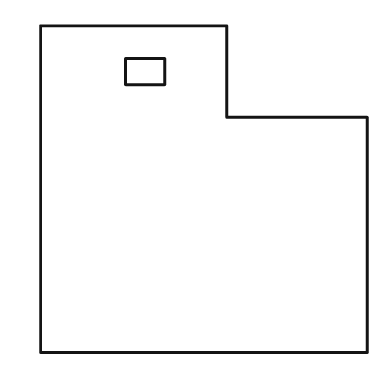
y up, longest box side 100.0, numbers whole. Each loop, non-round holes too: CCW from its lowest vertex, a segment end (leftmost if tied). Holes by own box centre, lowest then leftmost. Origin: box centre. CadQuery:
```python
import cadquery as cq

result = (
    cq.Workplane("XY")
    .moveTo(-50.0, -50.0)
    .lineTo(50.0, -50.0)
    .lineTo(50.0, 22.0)
    .lineTo(7.0, 22.0)
    .lineTo(7.0, 50.0)
    .lineTo(-50.0, 50.0)
    .close()
    .moveTo(-24.0, 32.0)
    .lineTo(-12.0, 32.0)
    .lineTo(-12.0, 40.0)
    .lineTo(-24.0, 40.0)
    .close()
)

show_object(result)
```